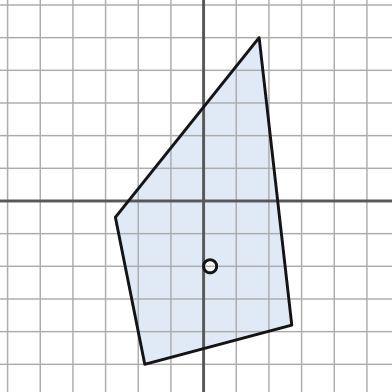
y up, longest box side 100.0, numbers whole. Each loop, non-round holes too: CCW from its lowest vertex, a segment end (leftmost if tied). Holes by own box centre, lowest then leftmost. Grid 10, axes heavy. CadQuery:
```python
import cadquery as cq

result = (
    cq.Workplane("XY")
    .moveTo(-18.0, -50.0)
    .lineTo(27.0, -38.0)
    .lineTo(17.0, 50.0)
    .lineTo(-27.0, -5.0)
    .close()
    .moveTo(2.0, -20.0)
    .circle(2.0)
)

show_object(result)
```